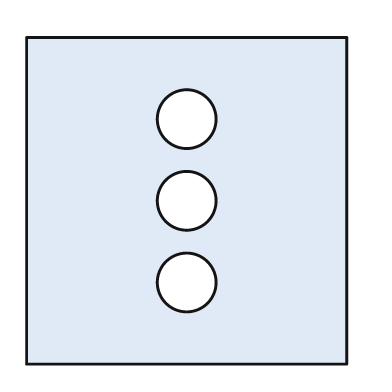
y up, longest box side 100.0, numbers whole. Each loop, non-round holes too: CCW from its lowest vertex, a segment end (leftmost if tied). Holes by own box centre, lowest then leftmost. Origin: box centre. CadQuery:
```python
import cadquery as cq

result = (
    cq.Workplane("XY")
    .moveTo(-49.0, -50.0)
    .lineTo(49.0, -50.0)
    .lineTo(49.0, 50.0)
    .lineTo(-49.0, 50.0)
    .close()
    .moveTo(0.0, -25.0)
    .circle(9.0)
    .moveTo(0.0, 0.0)
    .circle(9.0)
    .moveTo(0.0, 25.0)
    .circle(9.0)
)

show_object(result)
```